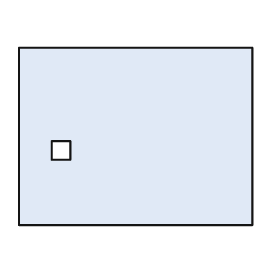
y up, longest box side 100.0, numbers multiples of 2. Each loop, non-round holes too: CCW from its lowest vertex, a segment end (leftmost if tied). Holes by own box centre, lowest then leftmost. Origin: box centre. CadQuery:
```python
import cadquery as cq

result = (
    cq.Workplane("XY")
    .moveTo(-50.0, -38.0)
    .lineTo(50.0, -38.0)
    .lineTo(50.0, 38.0)
    .lineTo(-50.0, 38.0)
    .close()
    .moveTo(-36.0, -10.0)
    .lineTo(-28.0, -10.0)
    .lineTo(-28.0, -2.0)
    .lineTo(-36.0, -2.0)
    .close()
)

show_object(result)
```